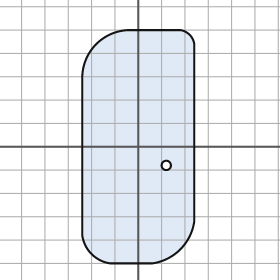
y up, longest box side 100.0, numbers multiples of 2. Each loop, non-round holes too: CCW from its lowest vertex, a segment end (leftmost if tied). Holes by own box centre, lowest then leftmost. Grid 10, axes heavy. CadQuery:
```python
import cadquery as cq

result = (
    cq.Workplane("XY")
    .moveTo(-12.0, -50.0)
    .lineTo(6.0, -50.0)
    .threePointArc((18.0, -44.0), (24.0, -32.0))
    .lineTo(24.0, 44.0)
    .threePointArc((22.0, 48.0), (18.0, 50.0))
    .lineTo(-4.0, 50.0)
    .threePointArc((-18.0, 44.0), (-24.0, 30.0))
    .lineTo(-24.0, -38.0)
    .threePointArc((-20.0, -46.0), (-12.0, -50.0))
    .close()
    .moveTo(12.0, -8.0)
    .circle(2.0)
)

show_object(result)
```